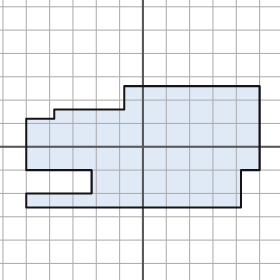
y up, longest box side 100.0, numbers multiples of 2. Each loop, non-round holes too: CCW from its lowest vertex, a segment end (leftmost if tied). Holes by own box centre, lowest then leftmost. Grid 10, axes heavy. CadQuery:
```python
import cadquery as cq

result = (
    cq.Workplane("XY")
    .moveTo(-50.0, -26.0)
    .lineTo(42.0, -26.0)
    .lineTo(42.0, -10.0)
    .lineTo(50.0, -10.0)
    .lineTo(50.0, 26.0)
    .lineTo(-8.0, 26.0)
    .lineTo(-8.0, 16.0)
    .lineTo(-38.0, 16.0)
    .lineTo(-38.0, 12.0)
    .lineTo(-50.0, 12.0)
    .lineTo(-50.0, -10.0)
    .lineTo(-22.0, -10.0)
    .lineTo(-22.0, -20.0)
    .lineTo(-50.0, -20.0)
    .close()
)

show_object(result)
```